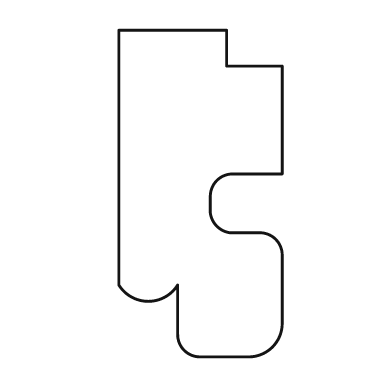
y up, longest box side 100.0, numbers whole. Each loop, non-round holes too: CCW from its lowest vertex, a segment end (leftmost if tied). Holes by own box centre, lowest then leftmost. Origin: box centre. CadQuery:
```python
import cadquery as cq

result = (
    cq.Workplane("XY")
    .moveTo(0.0, -50.0)
    .lineTo(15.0, -50.0)
    .threePointArc((22.0, -47.0), (25.0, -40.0))
    .lineTo(25.0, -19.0)
    .threePointArc((23.0, -14.0), (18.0, -12.0))
    .lineTo(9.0, -12.0)
    .threePointArc((5.0, -10.0), (3.0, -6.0))
    .lineTo(3.0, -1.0)
    .threePointArc((5.0, 4.0), (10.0, 6.0))
    .lineTo(25.0, 6.0)
    .lineTo(25.0, 39.0)
    .lineTo(8.0, 39.0)
    .lineTo(8.0, 50.0)
    .lineTo(-25.0, 50.0)
    .lineTo(-25.0, -28.0)
    .threePointArc((-16.0, -33.0), (-7.0, -28.0))
    .lineTo(-7.0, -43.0)
    .threePointArc((-5.0, -48.0), (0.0, -50.0))
    .close()
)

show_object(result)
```